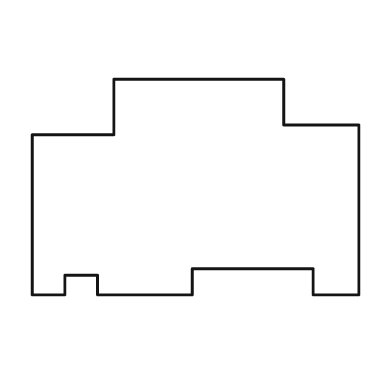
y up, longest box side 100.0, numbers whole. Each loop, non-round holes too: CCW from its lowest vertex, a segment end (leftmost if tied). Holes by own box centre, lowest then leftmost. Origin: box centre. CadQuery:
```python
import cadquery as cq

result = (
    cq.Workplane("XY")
    .moveTo(-50.0, -33.0)
    .lineTo(-40.0, -33.0)
    .lineTo(-40.0, -27.0)
    .lineTo(-30.0, -27.0)
    .lineTo(-30.0, -33.0)
    .lineTo(-1.0, -33.0)
    .lineTo(-1.0, -25.0)
    .lineTo(36.0, -25.0)
    .lineTo(36.0, -33.0)
    .lineTo(50.0, -33.0)
    .lineTo(50.0, 19.0)
    .lineTo(27.0, 19.0)
    .lineTo(27.0, 33.0)
    .lineTo(-25.0, 33.0)
    .lineTo(-25.0, 16.0)
    .lineTo(-50.0, 16.0)
    .close()
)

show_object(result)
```